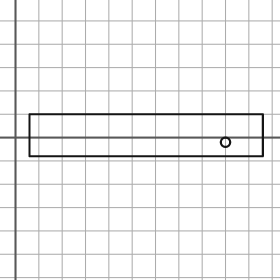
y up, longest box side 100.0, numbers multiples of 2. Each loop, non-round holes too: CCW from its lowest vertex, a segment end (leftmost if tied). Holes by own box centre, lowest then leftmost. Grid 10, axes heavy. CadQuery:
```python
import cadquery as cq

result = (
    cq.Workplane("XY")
    .moveTo(6.0, -8.0)
    .lineTo(106.0, -8.0)
    .lineTo(106.0, 10.0)
    .lineTo(6.0, 10.0)
    .close()
    .moveTo(90.0, -2.0)
    .circle(2.0)
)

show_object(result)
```